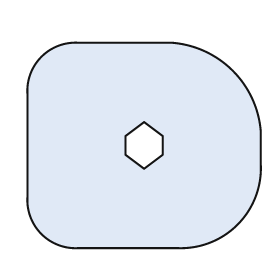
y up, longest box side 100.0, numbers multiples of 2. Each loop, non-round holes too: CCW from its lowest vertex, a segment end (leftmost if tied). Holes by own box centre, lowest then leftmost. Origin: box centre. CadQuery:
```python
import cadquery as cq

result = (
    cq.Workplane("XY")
    .moveTo(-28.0, -44.0)
    .lineTo(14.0, -44.0)
    .threePointArc((40.0, -34.0), (50.0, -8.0))
    .lineTo(50.0, 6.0)
    .threePointArc((38.0, 32.0), (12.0, 44.0))
    .lineTo(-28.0, 44.0)
    .threePointArc((-44.0, 38.0), (-50.0, 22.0))
    .lineTo(-50.0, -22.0)
    .threePointArc((-44.0, -38.0), (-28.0, -44.0))
    .close()
    .moveTo(0.0, -10.0)
    .lineTo(8.0, -4.0)
    .lineTo(8.0, 4.0)
    .lineTo(0.0, 10.0)
    .lineTo(-8.0, 4.0)
    .lineTo(-8.0, -4.0)
    .close()
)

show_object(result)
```